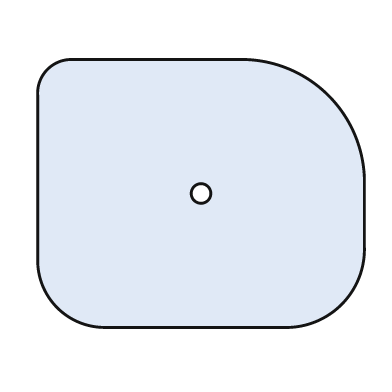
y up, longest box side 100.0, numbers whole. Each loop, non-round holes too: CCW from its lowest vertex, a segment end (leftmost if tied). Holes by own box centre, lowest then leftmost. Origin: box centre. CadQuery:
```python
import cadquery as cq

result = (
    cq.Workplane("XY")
    .moveTo(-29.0, -41.0)
    .lineTo(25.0, -41.0)
    .threePointArc((43.0, -34.0), (50.0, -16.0))
    .lineTo(50.0, 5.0)
    .threePointArc((39.0, 30.0), (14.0, 41.0))
    .lineTo(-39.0, 41.0)
    .threePointArc((-47.0, 38.0), (-50.0, 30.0))
    .lineTo(-50.0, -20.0)
    .threePointArc((-44.0, -35.0), (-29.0, -41.0))
    .close()
    .moveTo(0.0, 0.0)
    .circle(3.0)
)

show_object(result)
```